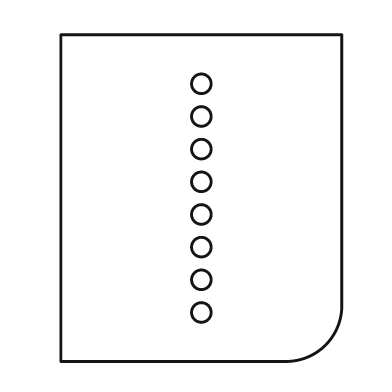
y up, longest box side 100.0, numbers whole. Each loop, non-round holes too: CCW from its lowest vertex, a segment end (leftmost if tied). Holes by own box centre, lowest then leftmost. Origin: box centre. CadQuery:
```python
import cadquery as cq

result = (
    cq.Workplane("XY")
    .moveTo(-43.0, -50.0)
    .lineTo(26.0, -50.0)
    .threePointArc((38.0, -45.0), (43.0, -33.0))
    .lineTo(43.0, 50.0)
    .lineTo(-43.0, 50.0)
    .close()
    .moveTo(0.0, -35.0)
    .circle(3.0)
    .moveTo(0.0, -25.0)
    .circle(3.0)
    .moveTo(0.0, -15.0)
    .circle(3.0)
    .moveTo(0.0, -5.0)
    .circle(3.0)
    .moveTo(0.0, 5.0)
    .circle(3.0)
    .moveTo(0.0, 15.0)
    .circle(3.0)
    .moveTo(0.0, 25.0)
    .circle(3.0)
    .moveTo(0.0, 35.0)
    .circle(3.0)
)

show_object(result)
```